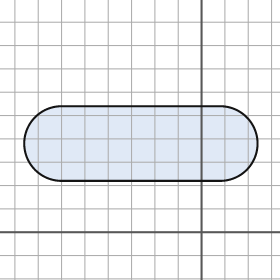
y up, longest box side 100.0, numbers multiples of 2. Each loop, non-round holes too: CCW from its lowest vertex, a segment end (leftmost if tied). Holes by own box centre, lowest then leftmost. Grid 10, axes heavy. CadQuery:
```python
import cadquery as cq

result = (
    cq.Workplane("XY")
    .moveTo(-60.0, 22.0)
    .lineTo(8.0, 22.0)
    .threePointArc((24.0, 38.0), (8.0, 54.0))
    .lineTo(-60.0, 54.0)
    .threePointArc((-76.0, 38.0), (-60.0, 22.0))
    .close()
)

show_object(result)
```